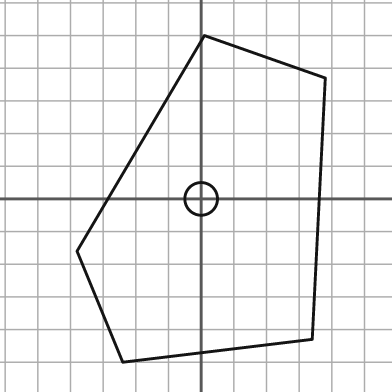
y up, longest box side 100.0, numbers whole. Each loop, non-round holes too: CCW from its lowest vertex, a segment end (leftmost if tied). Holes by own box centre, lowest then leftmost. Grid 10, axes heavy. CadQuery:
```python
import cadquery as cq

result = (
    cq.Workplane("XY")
    .moveTo(-24.0, -50.0)
    .lineTo(34.0, -43.0)
    .lineTo(38.0, 37.0)
    .lineTo(1.0, 50.0)
    .lineTo(-38.0, -16.0)
    .close()
    .moveTo(0.0, 0.0)
    .circle(5.0)
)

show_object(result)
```